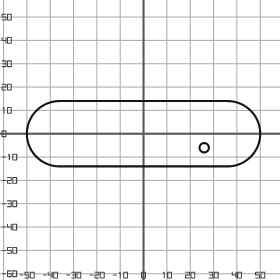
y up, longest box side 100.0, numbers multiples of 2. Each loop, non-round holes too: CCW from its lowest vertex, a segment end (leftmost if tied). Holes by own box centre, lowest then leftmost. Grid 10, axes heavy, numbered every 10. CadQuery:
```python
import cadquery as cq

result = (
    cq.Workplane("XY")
    .moveTo(-36.0, -14.0)
    .lineTo(36.0, -14.0)
    .threePointArc((50.0, 0.0), (36.0, 14.0))
    .lineTo(-36.0, 14.0)
    .threePointArc((-50.0, 0.0), (-36.0, -14.0))
    .close()
    .moveTo(26.0, -6.0)
    .circle(2.0)
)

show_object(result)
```